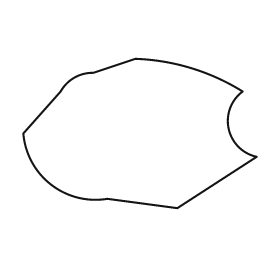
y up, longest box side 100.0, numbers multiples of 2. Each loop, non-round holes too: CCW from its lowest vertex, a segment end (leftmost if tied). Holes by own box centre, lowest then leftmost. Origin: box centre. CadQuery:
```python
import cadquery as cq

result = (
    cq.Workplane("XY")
    .moveTo(16.0, -32.0)
    .lineTo(50.0, -10.0)
    .threePointArc((38.0, 2.0), (44.0, 18.0))
    .threePointArc((22.0, 28.0), (-2.0, 32.0))
    .lineTo(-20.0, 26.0)
    .threePointArc((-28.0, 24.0), (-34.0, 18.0))
    .lineTo(-50.0, 0.0)
    .threePointArc((-38.0, -22.0), (-14.0, -28.0))
    .close()
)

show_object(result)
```